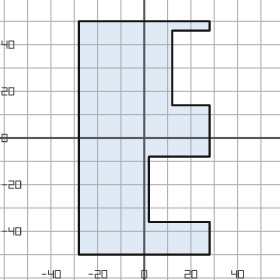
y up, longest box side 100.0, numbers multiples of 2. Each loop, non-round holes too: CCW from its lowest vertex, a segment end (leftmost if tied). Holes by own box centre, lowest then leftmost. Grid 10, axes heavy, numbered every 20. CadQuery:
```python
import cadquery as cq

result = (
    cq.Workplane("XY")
    .moveTo(-28.0, -50.0)
    .lineTo(28.0, -50.0)
    .lineTo(28.0, -36.0)
    .lineTo(2.0, -36.0)
    .lineTo(2.0, -8.0)
    .lineTo(28.0, -8.0)
    .lineTo(28.0, 14.0)
    .lineTo(12.0, 14.0)
    .lineTo(12.0, 46.0)
    .lineTo(28.0, 46.0)
    .lineTo(28.0, 50.0)
    .lineTo(-28.0, 50.0)
    .close()
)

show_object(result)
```